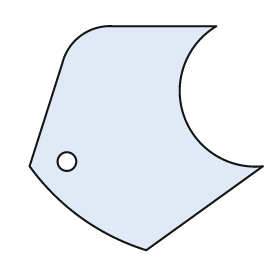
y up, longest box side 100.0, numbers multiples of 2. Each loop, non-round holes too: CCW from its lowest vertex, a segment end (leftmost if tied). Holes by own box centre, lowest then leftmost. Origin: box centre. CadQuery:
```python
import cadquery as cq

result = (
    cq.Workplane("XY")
    .moveTo(0.0, -48.0)
    .lineTo(50.0, -12.0)
    .threePointArc((16.0, 10.0), (30.0, 48.0))
    .lineTo(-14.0, 48.0)
    .threePointArc((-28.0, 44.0), (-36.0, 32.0))
    .lineTo(-50.0, -12.0)
    .threePointArc((-28.0, -34.0), (0.0, -48.0))
    .close()
    .moveTo(-34.0, -10.0)
    .circle(4.0)
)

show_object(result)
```